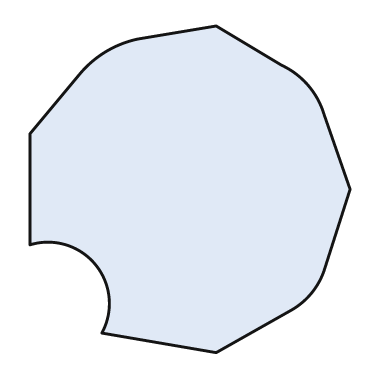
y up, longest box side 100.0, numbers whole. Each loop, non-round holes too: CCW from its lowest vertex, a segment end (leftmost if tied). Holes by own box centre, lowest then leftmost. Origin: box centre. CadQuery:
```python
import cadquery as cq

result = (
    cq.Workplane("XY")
    .moveTo(8.0, -50.0)
    .lineTo(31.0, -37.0)
    .threePointArc((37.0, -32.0), (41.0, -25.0))
    .lineTo(49.0, 0.0)
    .lineTo(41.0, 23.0)
    .threePointArc((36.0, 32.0), (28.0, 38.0))
    .lineTo(8.0, 50.0)
    .lineTo(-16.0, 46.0)
    .threePointArc((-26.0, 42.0), (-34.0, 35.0))
    .lineTo(-49.0, 17.0)
    .lineTo(-49.0, -17.0)
    .threePointArc((-29.0, -23.0), (-27.0, -44.0))
    .close()
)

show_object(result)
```